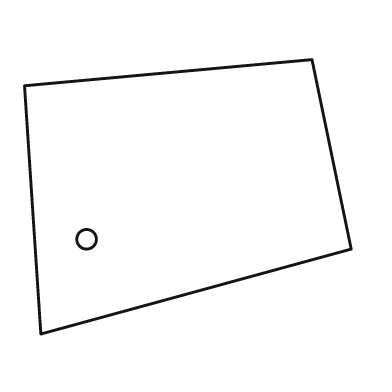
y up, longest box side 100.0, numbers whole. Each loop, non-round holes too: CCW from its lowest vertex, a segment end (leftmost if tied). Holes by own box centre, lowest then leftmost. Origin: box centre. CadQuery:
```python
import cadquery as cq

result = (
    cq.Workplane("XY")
    .moveTo(-45.0, -42.0)
    .lineTo(50.0, -16.0)
    .lineTo(38.0, 42.0)
    .lineTo(-50.0, 34.0)
    .close()
    .moveTo(-31.0, -13.0)
    .circle(3.0)
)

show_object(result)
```